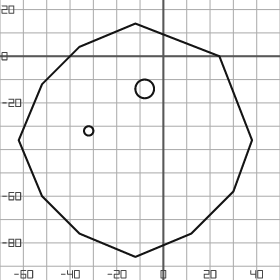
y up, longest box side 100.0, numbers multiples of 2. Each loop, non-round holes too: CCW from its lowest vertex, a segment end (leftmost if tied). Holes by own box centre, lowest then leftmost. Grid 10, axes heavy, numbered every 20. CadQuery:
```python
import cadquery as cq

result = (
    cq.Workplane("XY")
    .moveTo(-12.0, -86.0)
    .lineTo(12.0, -76.0)
    .lineTo(30.0, -58.0)
    .lineTo(38.0, -36.0)
    .lineTo(24.0, 0.0)
    .lineTo(-12.0, 14.0)
    .lineTo(-36.0, 4.0)
    .lineTo(-52.0, -12.0)
    .lineTo(-62.0, -36.0)
    .lineTo(-52.0, -60.0)
    .lineTo(-36.0, -76.0)
    .close()
    .moveTo(-32.0, -32.0)
    .circle(2.0)
    .moveTo(-8.0, -14.0)
    .circle(4.0)
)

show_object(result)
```